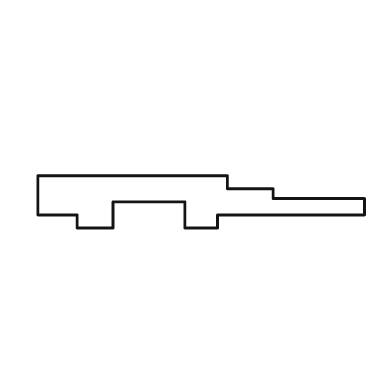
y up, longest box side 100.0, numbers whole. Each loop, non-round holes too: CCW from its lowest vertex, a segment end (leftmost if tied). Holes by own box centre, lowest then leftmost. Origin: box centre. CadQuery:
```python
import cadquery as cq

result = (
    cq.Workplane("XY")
    .moveTo(-38.0, -8.0)
    .lineTo(-27.0, -8.0)
    .lineTo(-27.0, 0.0)
    .lineTo(-5.0, 0.0)
    .lineTo(-5.0, -8.0)
    .lineTo(5.0, -8.0)
    .lineTo(5.0, -4.0)
    .lineTo(50.0, -4.0)
    .lineTo(50.0, 1.0)
    .lineTo(22.0, 1.0)
    .lineTo(22.0, 4.0)
    .lineTo(8.0, 4.0)
    .lineTo(8.0, 8.0)
    .lineTo(-50.0, 8.0)
    .lineTo(-50.0, -4.0)
    .lineTo(-38.0, -4.0)
    .close()
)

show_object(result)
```